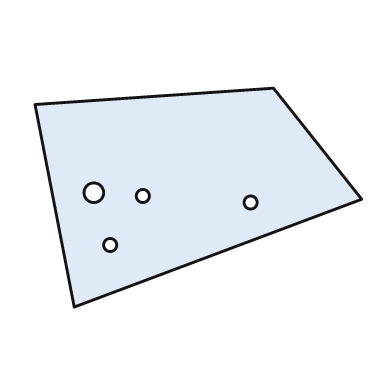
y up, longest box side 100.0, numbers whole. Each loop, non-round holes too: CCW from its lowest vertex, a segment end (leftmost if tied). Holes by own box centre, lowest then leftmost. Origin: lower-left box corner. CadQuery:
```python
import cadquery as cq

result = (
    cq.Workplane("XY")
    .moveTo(12.0, 0.0)
    .lineTo(100.0, 33.0)
    .lineTo(73.0, 67.0)
    .lineTo(0.0, 62.0)
    .close()
    .moveTo(23.0, 19.0)
    .circle(2.0)
    .moveTo(66.0, 32.0)
    .circle(2.0)
    .moveTo(33.0, 34.0)
    .circle(2.0)
    .moveTo(18.0, 35.0)
    .circle(3.0)
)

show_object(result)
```